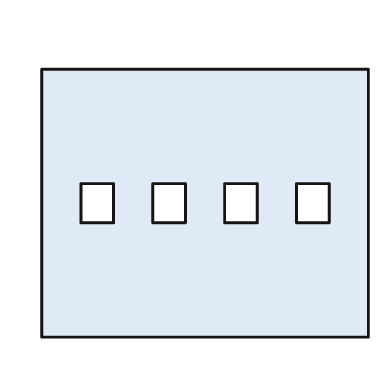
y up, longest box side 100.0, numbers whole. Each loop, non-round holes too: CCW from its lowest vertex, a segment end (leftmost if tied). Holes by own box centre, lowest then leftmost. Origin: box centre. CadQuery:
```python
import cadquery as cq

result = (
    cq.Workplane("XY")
    .moveTo(-50.0, -41.0)
    .lineTo(50.0, -41.0)
    .lineTo(50.0, 41.0)
    .lineTo(-50.0, 41.0)
    .close()
    .moveTo(-38.0, -6.0)
    .lineTo(-28.0, -6.0)
    .lineTo(-28.0, 6.0)
    .lineTo(-38.0, 6.0)
    .close()
    .moveTo(-16.0, -6.0)
    .lineTo(-6.0, -6.0)
    .lineTo(-6.0, 6.0)
    .lineTo(-16.0, 6.0)
    .close()
    .moveTo(6.0, -6.0)
    .lineTo(16.0, -6.0)
    .lineTo(16.0, 6.0)
    .lineTo(6.0, 6.0)
    .close()
    .moveTo(28.0, -6.0)
    .lineTo(38.0, -6.0)
    .lineTo(38.0, 6.0)
    .lineTo(28.0, 6.0)
    .close()
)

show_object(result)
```